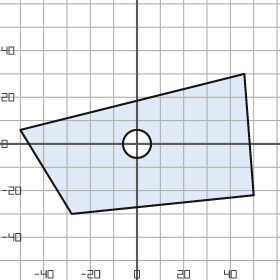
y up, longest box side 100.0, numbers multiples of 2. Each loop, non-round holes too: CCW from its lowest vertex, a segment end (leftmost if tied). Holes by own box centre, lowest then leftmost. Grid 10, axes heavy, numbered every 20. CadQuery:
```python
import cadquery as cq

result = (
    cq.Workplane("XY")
    .moveTo(-28.0, -30.0)
    .lineTo(50.0, -22.0)
    .lineTo(46.0, 30.0)
    .lineTo(-50.0, 6.0)
    .close()
    .moveTo(0.0, 0.0)
    .circle(6.0)
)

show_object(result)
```